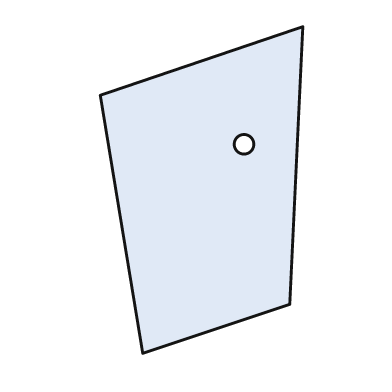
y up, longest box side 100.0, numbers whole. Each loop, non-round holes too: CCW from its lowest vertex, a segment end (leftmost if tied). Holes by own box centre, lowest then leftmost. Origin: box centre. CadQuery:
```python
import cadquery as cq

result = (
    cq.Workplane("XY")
    .moveTo(-18.0, -50.0)
    .lineTo(27.0, -35.0)
    .lineTo(31.0, 50.0)
    .lineTo(-31.0, 29.0)
    .close()
    .moveTo(13.0, 14.0)
    .circle(3.0)
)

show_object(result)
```